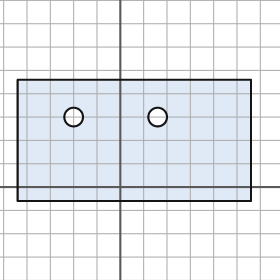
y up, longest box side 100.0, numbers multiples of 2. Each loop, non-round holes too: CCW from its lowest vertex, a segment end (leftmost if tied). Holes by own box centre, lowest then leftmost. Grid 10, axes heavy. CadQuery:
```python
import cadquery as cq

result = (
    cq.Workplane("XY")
    .moveTo(-44.0, -6.0)
    .lineTo(56.0, -6.0)
    .lineTo(56.0, 46.0)
    .lineTo(-44.0, 46.0)
    .close()
    .moveTo(-20.0, 30.0)
    .circle(4.0)
    .moveTo(16.0, 30.0)
    .circle(4.0)
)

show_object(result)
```